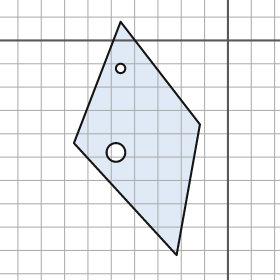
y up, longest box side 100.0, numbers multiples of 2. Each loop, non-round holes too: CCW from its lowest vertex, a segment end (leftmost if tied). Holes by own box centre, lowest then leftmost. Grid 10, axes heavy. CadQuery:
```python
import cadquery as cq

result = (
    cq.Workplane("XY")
    .moveTo(-22.0, -92.0)
    .lineTo(-12.0, -36.0)
    .lineTo(-46.0, 8.0)
    .lineTo(-66.0, -44.0)
    .close()
    .moveTo(-48.0, -48.0)
    .circle(4.0)
    .moveTo(-46.0, -12.0)
    .circle(2.0)
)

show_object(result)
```